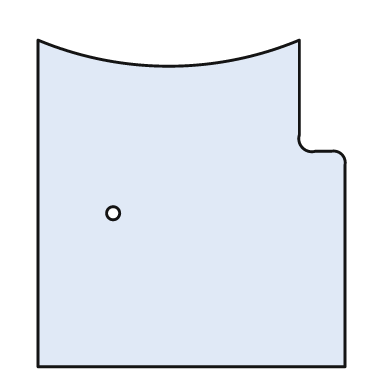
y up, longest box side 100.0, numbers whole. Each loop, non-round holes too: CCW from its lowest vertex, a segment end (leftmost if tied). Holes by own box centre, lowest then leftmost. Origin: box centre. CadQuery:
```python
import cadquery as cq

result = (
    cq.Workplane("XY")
    .moveTo(-47.0, -50.0)
    .lineTo(47.0, -50.0)
    .lineTo(47.0, 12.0)
    .threePointArc((46.0, 15.0), (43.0, 16.0))
    .lineTo(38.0, 16.0)
    .threePointArc((34.0, 17.0), (33.0, 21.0))
    .lineTo(33.0, 50.0)
    .threePointArc((-7.0, 42.0), (-47.0, 50.0))
    .close()
    .moveTo(-24.0, -3.0)
    .circle(2.0)
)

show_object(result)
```